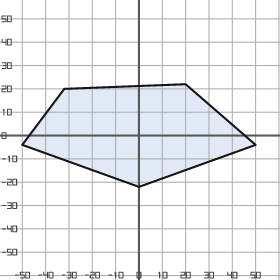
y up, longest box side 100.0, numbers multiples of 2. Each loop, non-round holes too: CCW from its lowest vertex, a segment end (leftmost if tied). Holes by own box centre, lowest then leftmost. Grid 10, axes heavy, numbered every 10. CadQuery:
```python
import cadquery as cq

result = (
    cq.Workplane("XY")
    .moveTo(0.0, -22.0)
    .lineTo(50.0, -4.0)
    .lineTo(20.0, 22.0)
    .lineTo(-32.0, 20.0)
    .lineTo(-50.0, -4.0)
    .close()
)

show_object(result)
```